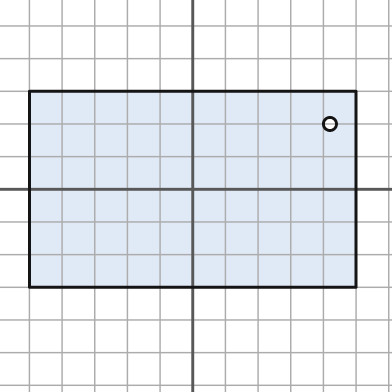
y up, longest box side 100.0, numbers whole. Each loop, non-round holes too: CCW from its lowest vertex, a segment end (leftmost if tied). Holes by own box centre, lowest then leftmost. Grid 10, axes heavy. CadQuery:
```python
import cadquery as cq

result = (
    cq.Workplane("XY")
    .moveTo(-50.0, -30.0)
    .lineTo(50.0, -30.0)
    .lineTo(50.0, 30.0)
    .lineTo(-50.0, 30.0)
    .close()
    .moveTo(42.0, 20.0)
    .circle(2.0)
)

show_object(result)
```